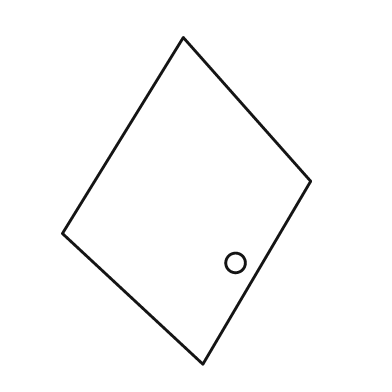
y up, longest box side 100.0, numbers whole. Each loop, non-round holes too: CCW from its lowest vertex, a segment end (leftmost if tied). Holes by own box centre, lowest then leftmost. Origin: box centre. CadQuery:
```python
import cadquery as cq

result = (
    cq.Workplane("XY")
    .moveTo(5.0, -50.0)
    .lineTo(38.0, 6.0)
    .lineTo(-1.0, 50.0)
    .lineTo(-38.0, -10.0)
    .close()
    .moveTo(15.0, -19.0)
    .circle(3.0)
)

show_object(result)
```